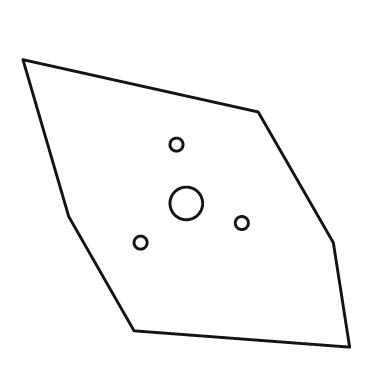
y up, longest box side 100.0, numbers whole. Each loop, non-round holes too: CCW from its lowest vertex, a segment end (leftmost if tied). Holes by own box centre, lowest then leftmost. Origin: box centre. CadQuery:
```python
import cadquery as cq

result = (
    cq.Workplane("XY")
    .moveTo(50.0, -44.0)
    .lineTo(45.0, -12.0)
    .lineTo(22.0, 28.0)
    .lineTo(-50.0, 44.0)
    .lineTo(-36.0, -4.0)
    .lineTo(-16.0, -39.0)
    .close()
    .moveTo(-14.0, -12.0)
    .circle(2.0)
    .moveTo(17.0, -6.0)
    .circle(2.0)
    .moveTo(0.0, 0.0)
    .circle(5.0)
    .moveTo(-3.0, 18.0)
    .circle(2.0)
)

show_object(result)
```